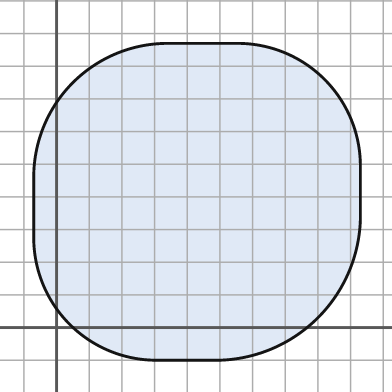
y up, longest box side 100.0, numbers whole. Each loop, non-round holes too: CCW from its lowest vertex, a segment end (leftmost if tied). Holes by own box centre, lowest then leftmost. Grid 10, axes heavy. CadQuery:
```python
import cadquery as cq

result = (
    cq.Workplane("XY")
    .moveTo(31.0, -10.0)
    .lineTo(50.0, -10.0)
    .threePointArc((80.0, 3.0), (93.0, 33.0))
    .lineTo(93.0, 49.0)
    .threePointArc((82.0, 76.0), (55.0, 87.0))
    .lineTo(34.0, 87.0)
    .threePointArc((5.0, 75.0), (-7.0, 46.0))
    .lineTo(-7.0, 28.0)
    .threePointArc((4.0, 1.0), (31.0, -10.0))
    .close()
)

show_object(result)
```